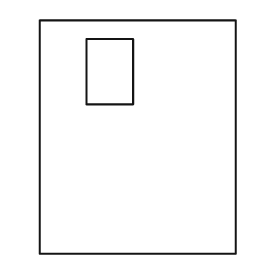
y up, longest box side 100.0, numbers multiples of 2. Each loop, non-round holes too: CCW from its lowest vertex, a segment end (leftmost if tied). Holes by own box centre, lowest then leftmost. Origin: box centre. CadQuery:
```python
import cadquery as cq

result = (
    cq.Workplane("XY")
    .moveTo(-42.0, -50.0)
    .lineTo(42.0, -50.0)
    .lineTo(42.0, 50.0)
    .lineTo(-42.0, 50.0)
    .close()
    .moveTo(-22.0, 14.0)
    .lineTo(-2.0, 14.0)
    .lineTo(-2.0, 42.0)
    .lineTo(-22.0, 42.0)
    .close()
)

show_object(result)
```